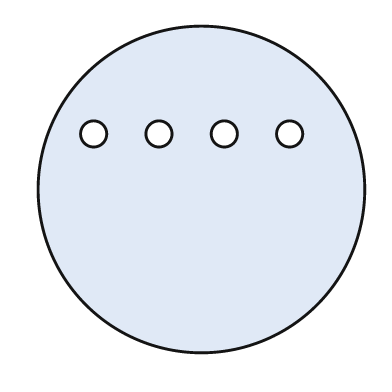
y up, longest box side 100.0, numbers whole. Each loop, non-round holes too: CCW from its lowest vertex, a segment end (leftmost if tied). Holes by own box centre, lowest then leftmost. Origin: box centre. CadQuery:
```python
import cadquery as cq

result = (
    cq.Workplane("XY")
    .moveTo(0.0, 0.0)
    .circle(50.0)
    .moveTo(-33.0, 17.0)
    .circle(4.0)
    .moveTo(-13.0, 17.0)
    .circle(4.0)
    .moveTo(7.0, 17.0)
    .circle(4.0)
    .moveTo(27.0, 17.0)
    .circle(4.0)
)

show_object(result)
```